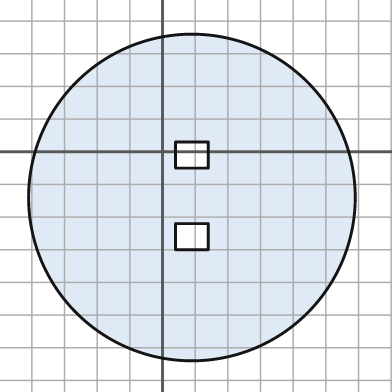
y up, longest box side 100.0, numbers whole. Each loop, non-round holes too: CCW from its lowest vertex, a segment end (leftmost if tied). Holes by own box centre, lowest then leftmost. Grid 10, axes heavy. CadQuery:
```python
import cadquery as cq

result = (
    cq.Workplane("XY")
    .moveTo(9.0, -14.0)
    .circle(50.0)
    .moveTo(4.0, -30.0)
    .lineTo(14.0, -30.0)
    .lineTo(14.0, -22.0)
    .lineTo(4.0, -22.0)
    .close()
    .moveTo(4.0, -5.0)
    .lineTo(14.0, -5.0)
    .lineTo(14.0, 3.0)
    .lineTo(4.0, 3.0)
    .close()
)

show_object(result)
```